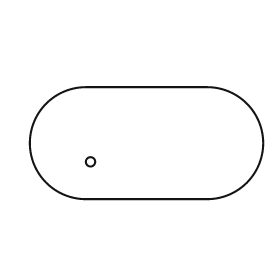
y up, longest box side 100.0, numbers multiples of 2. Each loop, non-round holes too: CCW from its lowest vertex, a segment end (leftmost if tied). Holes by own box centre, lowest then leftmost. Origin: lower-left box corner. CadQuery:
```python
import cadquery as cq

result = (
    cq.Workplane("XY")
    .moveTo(24.0, 0.0)
    .lineTo(76.0, 0.0)
    .threePointArc((100.0, 24.0), (76.0, 48.0))
    .lineTo(24.0, 48.0)
    .threePointArc((0.0, 24.0), (24.0, 0.0))
    .close()
    .moveTo(26.0, 16.0)
    .circle(2.0)
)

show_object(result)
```